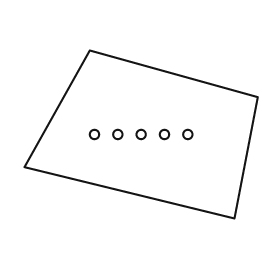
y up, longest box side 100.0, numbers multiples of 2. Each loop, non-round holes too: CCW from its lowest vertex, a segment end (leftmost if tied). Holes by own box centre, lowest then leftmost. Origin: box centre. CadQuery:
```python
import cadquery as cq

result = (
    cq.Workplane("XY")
    .moveTo(40.0, -36.0)
    .lineTo(50.0, 16.0)
    .lineTo(-22.0, 36.0)
    .lineTo(-50.0, -14.0)
    .close()
    .moveTo(-20.0, 0.0)
    .circle(2.0)
    .moveTo(-10.0, 0.0)
    .circle(2.0)
    .moveTo(0.0, 0.0)
    .circle(2.0)
    .moveTo(10.0, 0.0)
    .circle(2.0)
    .moveTo(20.0, 0.0)
    .circle(2.0)
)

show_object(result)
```